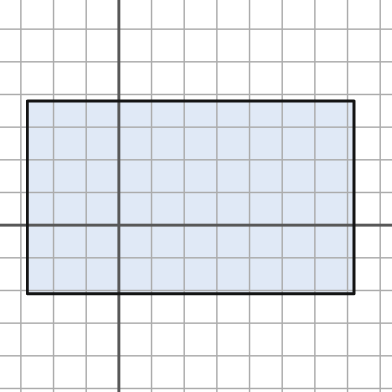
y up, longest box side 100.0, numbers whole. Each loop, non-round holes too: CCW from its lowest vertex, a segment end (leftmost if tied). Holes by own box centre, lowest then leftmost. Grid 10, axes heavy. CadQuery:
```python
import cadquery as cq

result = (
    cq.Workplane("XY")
    .moveTo(-28.0, -21.0)
    .lineTo(72.0, -21.0)
    .lineTo(72.0, 38.0)
    .lineTo(-28.0, 38.0)
    .close()
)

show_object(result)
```